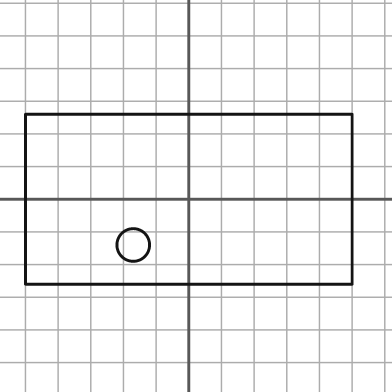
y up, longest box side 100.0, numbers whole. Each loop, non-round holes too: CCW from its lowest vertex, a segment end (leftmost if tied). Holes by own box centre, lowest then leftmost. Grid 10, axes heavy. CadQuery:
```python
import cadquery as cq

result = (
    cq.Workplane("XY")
    .moveTo(-50.0, -26.0)
    .lineTo(50.0, -26.0)
    .lineTo(50.0, 26.0)
    .lineTo(-50.0, 26.0)
    .close()
    .moveTo(-17.0, -14.0)
    .circle(5.0)
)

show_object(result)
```